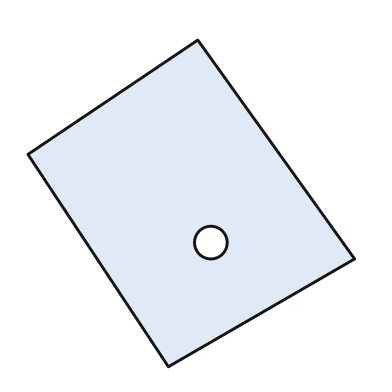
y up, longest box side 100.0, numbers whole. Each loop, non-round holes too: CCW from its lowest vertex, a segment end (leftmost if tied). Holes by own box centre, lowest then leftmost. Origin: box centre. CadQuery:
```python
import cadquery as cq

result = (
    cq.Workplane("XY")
    .moveTo(-7.0, -50.0)
    .lineTo(50.0, -17.0)
    .lineTo(2.0, 50.0)
    .lineTo(-50.0, 15.0)
    .close()
    .moveTo(6.0, -12.0)
    .circle(5.0)
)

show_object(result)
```